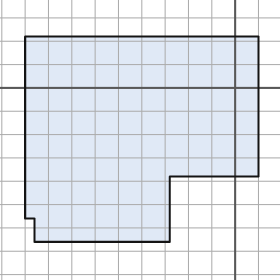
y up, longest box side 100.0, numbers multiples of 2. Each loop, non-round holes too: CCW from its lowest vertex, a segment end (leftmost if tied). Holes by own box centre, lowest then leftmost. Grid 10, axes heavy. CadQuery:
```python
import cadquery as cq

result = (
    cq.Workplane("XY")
    .moveTo(-86.0, -66.0)
    .lineTo(-28.0, -66.0)
    .lineTo(-28.0, -38.0)
    .lineTo(10.0, -38.0)
    .lineTo(10.0, 22.0)
    .lineTo(-90.0, 22.0)
    .lineTo(-90.0, -56.0)
    .lineTo(-86.0, -56.0)
    .close()
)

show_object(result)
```